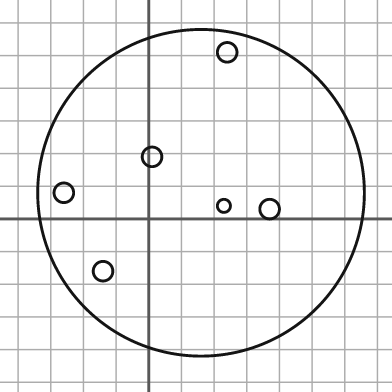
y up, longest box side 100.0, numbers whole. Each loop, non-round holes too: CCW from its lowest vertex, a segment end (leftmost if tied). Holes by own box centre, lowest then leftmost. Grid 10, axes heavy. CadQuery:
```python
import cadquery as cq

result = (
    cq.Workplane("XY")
    .moveTo(16.0, 8.0)
    .circle(50.0)
    .moveTo(-14.0, -16.0)
    .circle(3.0)
    .moveTo(37.0, 3.0)
    .circle(3.0)
    .moveTo(23.0, 4.0)
    .circle(2.0)
    .moveTo(-26.0, 8.0)
    .circle(3.0)
    .moveTo(1.0, 19.0)
    .circle(3.0)
    .moveTo(24.0, 51.0)
    .circle(3.0)
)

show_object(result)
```